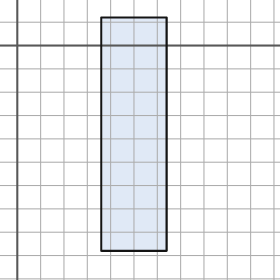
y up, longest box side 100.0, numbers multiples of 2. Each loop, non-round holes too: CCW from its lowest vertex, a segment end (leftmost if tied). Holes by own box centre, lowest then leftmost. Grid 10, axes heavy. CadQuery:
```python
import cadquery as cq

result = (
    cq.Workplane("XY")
    .moveTo(36.0, -88.0)
    .lineTo(64.0, -88.0)
    .lineTo(64.0, 12.0)
    .lineTo(36.0, 12.0)
    .close()
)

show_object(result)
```